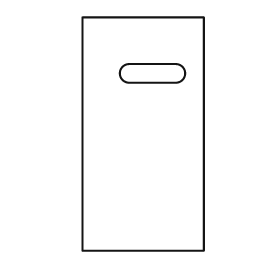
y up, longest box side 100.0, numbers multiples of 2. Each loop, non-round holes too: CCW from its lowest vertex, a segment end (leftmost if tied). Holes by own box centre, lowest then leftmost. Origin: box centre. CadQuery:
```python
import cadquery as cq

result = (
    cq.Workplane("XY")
    .moveTo(-26.0, -50.0)
    .lineTo(26.0, -50.0)
    .lineTo(26.0, 50.0)
    .lineTo(-26.0, 50.0)
    .close()
    .moveTo(-6.0, 22.0)
    .lineTo(14.0, 22.0)
    .threePointArc((18.0, 26.0), (14.0, 30.0))
    .lineTo(-6.0, 30.0)
    .threePointArc((-10.0, 26.0), (-6.0, 22.0))
    .close()
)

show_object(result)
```